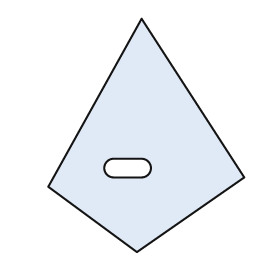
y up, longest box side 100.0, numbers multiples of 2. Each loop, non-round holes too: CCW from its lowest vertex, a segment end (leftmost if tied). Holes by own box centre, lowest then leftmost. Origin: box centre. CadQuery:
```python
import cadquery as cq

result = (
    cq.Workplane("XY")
    .moveTo(-4.0, -50.0)
    .lineTo(42.0, -18.0)
    .lineTo(-2.0, 50.0)
    .lineTo(-42.0, -22.0)
    .close()
    .moveTo(-14.0, -18.0)
    .lineTo(-2.0, -18.0)
    .threePointArc((2.0, -14.0), (-2.0, -10.0))
    .lineTo(-14.0, -10.0)
    .threePointArc((-18.0, -14.0), (-14.0, -18.0))
    .close()
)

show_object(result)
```